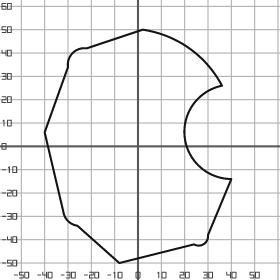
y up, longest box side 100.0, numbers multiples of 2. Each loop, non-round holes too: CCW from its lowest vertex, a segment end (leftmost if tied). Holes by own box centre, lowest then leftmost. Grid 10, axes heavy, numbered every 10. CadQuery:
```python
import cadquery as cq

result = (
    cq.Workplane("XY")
    .moveTo(-8.0, -50.0)
    .lineTo(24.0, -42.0)
    .threePointArc((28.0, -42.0), (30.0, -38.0))
    .lineTo(40.0, -14.0)
    .threePointArc((20.0, 4.0), (36.0, 26.0))
    .threePointArc((22.0, 42.0), (2.0, 50.0))
    .lineTo(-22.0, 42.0)
    .threePointArc((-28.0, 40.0), (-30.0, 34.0))
    .lineTo(-40.0, 6.0)
    .lineTo(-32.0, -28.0)
    .threePointArc((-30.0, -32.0), (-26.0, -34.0))
    .close()
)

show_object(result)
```